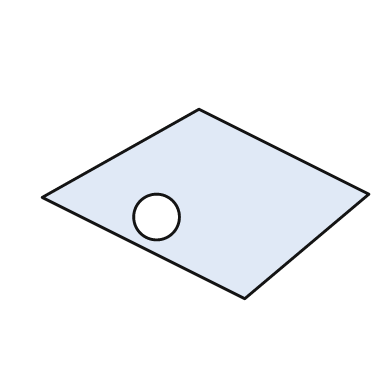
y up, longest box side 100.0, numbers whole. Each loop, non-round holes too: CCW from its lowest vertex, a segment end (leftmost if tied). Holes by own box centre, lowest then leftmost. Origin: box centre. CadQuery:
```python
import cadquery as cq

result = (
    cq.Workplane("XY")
    .moveTo(12.0, -29.0)
    .lineTo(50.0, 3.0)
    .lineTo(-2.0, 29.0)
    .lineTo(-50.0, 2.0)
    .close()
    .moveTo(-15.0, -4.0)
    .circle(7.0)
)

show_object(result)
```